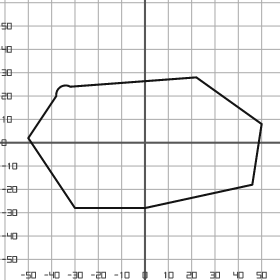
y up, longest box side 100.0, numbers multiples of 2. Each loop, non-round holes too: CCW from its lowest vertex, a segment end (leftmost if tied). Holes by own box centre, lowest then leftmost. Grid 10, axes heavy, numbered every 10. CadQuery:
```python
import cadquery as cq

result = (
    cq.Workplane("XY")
    .moveTo(-30.0, -28.0)
    .lineTo(0.0, -28.0)
    .lineTo(46.0, -18.0)
    .lineTo(50.0, 8.0)
    .lineTo(22.0, 28.0)
    .lineTo(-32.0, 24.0)
    .threePointArc((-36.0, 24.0), (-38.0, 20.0))
    .lineTo(-50.0, 2.0)
    .close()
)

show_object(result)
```